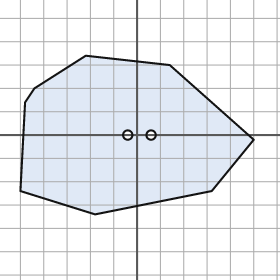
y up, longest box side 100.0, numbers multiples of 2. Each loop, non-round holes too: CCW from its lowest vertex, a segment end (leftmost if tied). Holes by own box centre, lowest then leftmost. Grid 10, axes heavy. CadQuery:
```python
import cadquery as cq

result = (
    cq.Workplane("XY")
    .moveTo(-18.0, -34.0)
    .lineTo(32.0, -24.0)
    .lineTo(50.0, -2.0)
    .lineTo(14.0, 30.0)
    .lineTo(-22.0, 34.0)
    .lineTo(-44.0, 20.0)
    .lineTo(-48.0, 14.0)
    .lineTo(-50.0, -24.0)
    .close()
    .moveTo(-4.0, 0.0)
    .circle(2.0)
    .moveTo(6.0, 0.0)
    .circle(2.0)
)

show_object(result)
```